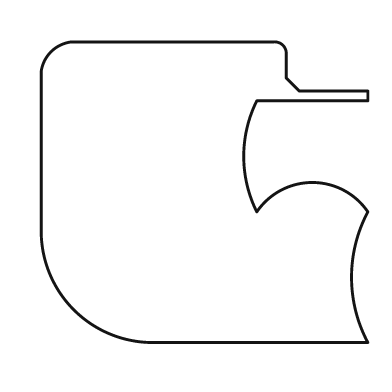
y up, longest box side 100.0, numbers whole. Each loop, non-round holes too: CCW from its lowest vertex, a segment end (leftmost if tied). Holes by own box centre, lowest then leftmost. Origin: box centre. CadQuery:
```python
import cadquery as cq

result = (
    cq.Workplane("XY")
    .moveTo(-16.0, -46.0)
    .lineTo(50.0, -46.0)
    .threePointArc((45.0, -26.0), (50.0, -6.0))
    .threePointArc((33.0, 3.0), (16.0, -6.0))
    .threePointArc((12.0, 11.0), (16.0, 28.0))
    .lineTo(50.0, 28.0)
    .lineTo(50.0, 31.0)
    .lineTo(29.0, 31.0)
    .lineTo(25.0, 35.0)
    .lineTo(25.0, 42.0)
    .threePointArc((24.0, 45.0), (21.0, 46.0))
    .lineTo(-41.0, 46.0)
    .threePointArc((-47.0, 43.0), (-50.0, 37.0))
    .lineTo(-50.0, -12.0)
    .threePointArc((-40.0, -36.0), (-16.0, -46.0))
    .close()
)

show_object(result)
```